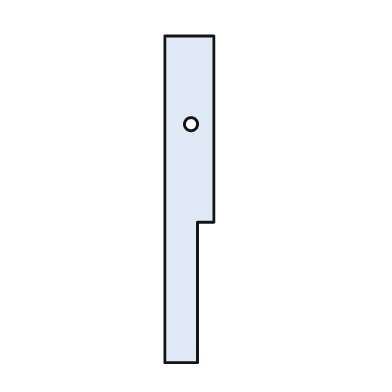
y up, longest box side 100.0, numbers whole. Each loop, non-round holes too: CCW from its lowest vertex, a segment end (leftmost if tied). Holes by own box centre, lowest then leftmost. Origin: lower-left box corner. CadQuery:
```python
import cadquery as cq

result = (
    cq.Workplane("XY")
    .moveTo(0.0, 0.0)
    .lineTo(10.0, 0.0)
    .lineTo(10.0, 43.0)
    .lineTo(15.0, 43.0)
    .lineTo(15.0, 100.0)
    .lineTo(0.0, 100.0)
    .close()
    .moveTo(8.0, 73.0)
    .circle(2.0)
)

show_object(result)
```